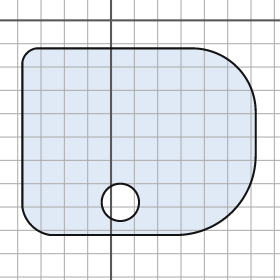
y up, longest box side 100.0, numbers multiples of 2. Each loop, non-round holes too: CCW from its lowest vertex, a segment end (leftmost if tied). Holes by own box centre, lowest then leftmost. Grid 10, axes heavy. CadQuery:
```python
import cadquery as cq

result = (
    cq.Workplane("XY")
    .moveTo(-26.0, -92.0)
    .lineTo(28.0, -92.0)
    .threePointArc((52.0, -82.0), (62.0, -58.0))
    .lineTo(62.0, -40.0)
    .threePointArc((54.0, -20.0), (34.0, -12.0))
    .lineTo(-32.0, -12.0)
    .threePointArc((-36.0, -14.0), (-38.0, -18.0))
    .lineTo(-38.0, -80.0)
    .threePointArc((-34.0, -88.0), (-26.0, -92.0))
    .close()
    .moveTo(4.0, -78.0)
    .circle(8.0)
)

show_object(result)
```